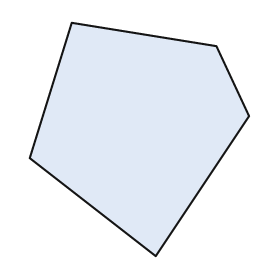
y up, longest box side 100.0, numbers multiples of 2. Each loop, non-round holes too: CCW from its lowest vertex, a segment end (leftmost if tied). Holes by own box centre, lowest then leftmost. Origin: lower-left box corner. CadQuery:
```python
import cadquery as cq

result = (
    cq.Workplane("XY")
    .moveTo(54.0, 0.0)
    .lineTo(94.0, 60.0)
    .lineTo(80.0, 90.0)
    .lineTo(18.0, 100.0)
    .lineTo(0.0, 42.0)
    .close()
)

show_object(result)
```